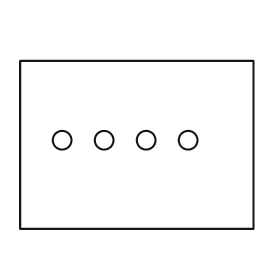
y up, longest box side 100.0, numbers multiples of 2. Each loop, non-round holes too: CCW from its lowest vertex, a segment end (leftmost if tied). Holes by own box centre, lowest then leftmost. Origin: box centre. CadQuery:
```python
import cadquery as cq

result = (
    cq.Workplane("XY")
    .moveTo(-50.0, -36.0)
    .lineTo(50.0, -36.0)
    .lineTo(50.0, 36.0)
    .lineTo(-50.0, 36.0)
    .close()
    .moveTo(-32.0, 2.0)
    .circle(4.0)
    .moveTo(-14.0, 2.0)
    .circle(4.0)
    .moveTo(4.0, 2.0)
    .circle(4.0)
    .moveTo(22.0, 2.0)
    .circle(4.0)
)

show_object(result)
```